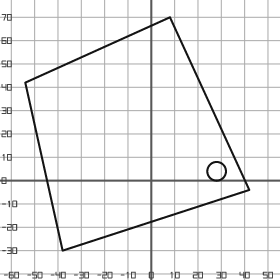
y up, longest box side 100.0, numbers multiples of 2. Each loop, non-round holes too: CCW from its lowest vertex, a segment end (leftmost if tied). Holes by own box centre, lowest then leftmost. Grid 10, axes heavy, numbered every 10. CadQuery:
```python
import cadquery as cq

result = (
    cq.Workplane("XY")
    .moveTo(-38.0, -30.0)
    .lineTo(42.0, -4.0)
    .lineTo(8.0, 70.0)
    .lineTo(-54.0, 42.0)
    .close()
    .moveTo(28.0, 4.0)
    .circle(4.0)
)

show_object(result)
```